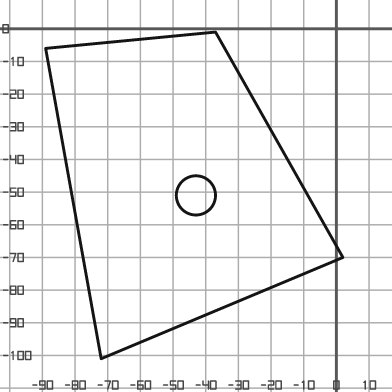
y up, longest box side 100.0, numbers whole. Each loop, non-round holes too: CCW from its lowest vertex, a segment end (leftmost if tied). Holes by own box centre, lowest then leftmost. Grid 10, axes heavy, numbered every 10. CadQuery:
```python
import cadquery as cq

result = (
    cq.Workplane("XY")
    .moveTo(-72.0, -101.0)
    .lineTo(2.0, -70.0)
    .lineTo(-37.0, -1.0)
    .lineTo(-89.0, -6.0)
    .close()
    .moveTo(-43.0, -51.0)
    .circle(6.0)
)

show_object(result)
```